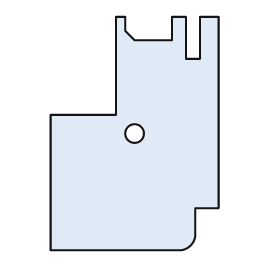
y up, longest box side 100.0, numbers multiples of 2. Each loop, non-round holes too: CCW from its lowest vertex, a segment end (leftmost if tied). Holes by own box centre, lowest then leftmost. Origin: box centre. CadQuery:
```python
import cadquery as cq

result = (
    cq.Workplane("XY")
    .moveTo(-36.0, -50.0)
    .lineTo(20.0, -50.0)
    .threePointArc((24.0, -48.0), (26.0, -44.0))
    .lineTo(26.0, -32.0)
    .lineTo(36.0, -32.0)
    .lineTo(36.0, 50.0)
    .lineTo(28.0, 50.0)
    .lineTo(28.0, 32.0)
    .lineTo(22.0, 32.0)
    .lineTo(22.0, 50.0)
    .lineTo(16.0, 50.0)
    .lineTo(16.0, 40.0)
    .lineTo(0.0, 40.0)
    .lineTo(-4.0, 44.0)
    .lineTo(-4.0, 50.0)
    .lineTo(-8.0, 50.0)
    .lineTo(-8.0, 8.0)
    .lineTo(-36.0, 8.0)
    .close()
    .moveTo(0.0, 0.0)
    .circle(4.0)
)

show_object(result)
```